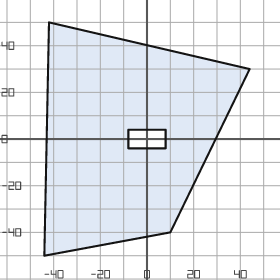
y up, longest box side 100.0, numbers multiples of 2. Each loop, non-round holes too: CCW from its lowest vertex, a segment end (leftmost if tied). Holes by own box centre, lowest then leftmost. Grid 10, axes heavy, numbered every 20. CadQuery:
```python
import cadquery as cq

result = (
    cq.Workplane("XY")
    .moveTo(-44.0, -50.0)
    .lineTo(10.0, -40.0)
    .lineTo(44.0, 30.0)
    .lineTo(-42.0, 50.0)
    .close()
    .moveTo(-8.0, -4.0)
    .lineTo(8.0, -4.0)
    .lineTo(8.0, 4.0)
    .lineTo(-8.0, 4.0)
    .close()
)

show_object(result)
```